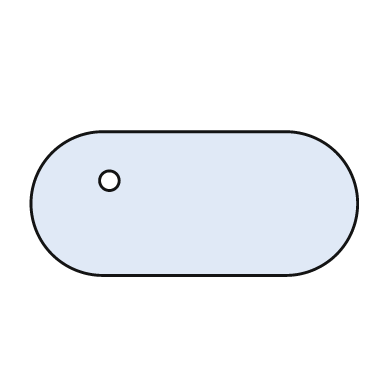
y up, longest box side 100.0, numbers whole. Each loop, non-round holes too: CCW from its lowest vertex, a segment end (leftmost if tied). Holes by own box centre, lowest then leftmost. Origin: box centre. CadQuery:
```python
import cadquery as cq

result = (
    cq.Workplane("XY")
    .moveTo(-28.0, -22.0)
    .lineTo(28.0, -22.0)
    .threePointArc((50.0, 0.0), (28.0, 22.0))
    .lineTo(-28.0, 22.0)
    .threePointArc((-50.0, 0.0), (-28.0, -22.0))
    .close()
    .moveTo(-26.0, 7.0)
    .circle(3.0)
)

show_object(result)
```